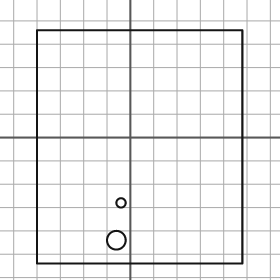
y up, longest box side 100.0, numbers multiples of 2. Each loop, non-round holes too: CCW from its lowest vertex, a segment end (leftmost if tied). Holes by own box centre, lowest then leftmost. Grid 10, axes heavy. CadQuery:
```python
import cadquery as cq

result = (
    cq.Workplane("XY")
    .moveTo(-40.0, -54.0)
    .lineTo(48.0, -54.0)
    .lineTo(48.0, 46.0)
    .lineTo(-40.0, 46.0)
    .close()
    .moveTo(-6.0, -44.0)
    .circle(4.0)
    .moveTo(-4.0, -28.0)
    .circle(2.0)
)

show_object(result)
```